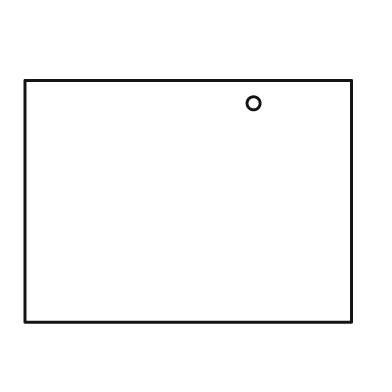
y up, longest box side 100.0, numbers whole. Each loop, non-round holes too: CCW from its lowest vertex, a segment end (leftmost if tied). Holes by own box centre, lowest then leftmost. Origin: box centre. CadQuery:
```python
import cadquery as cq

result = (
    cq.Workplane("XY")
    .moveTo(-50.0, -37.0)
    .lineTo(50.0, -37.0)
    .lineTo(50.0, 37.0)
    .lineTo(-50.0, 37.0)
    .close()
    .moveTo(20.0, 30.0)
    .circle(2.0)
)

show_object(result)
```